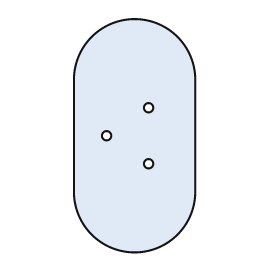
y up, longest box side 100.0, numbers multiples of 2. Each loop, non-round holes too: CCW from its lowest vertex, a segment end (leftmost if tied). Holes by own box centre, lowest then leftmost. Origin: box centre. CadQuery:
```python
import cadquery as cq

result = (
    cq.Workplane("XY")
    .moveTo(-26.0, -24.0)
    .threePointArc((0.0, -50.0), (26.0, -24.0))
    .lineTo(26.0, 24.0)
    .threePointArc((0.0, 50.0), (-26.0, 24.0))
    .close()
    .moveTo(6.0, -12.0)
    .circle(2.0)
    .moveTo(-12.0, 0.0)
    .circle(2.0)
    .moveTo(6.0, 12.0)
    .circle(2.0)
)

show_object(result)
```